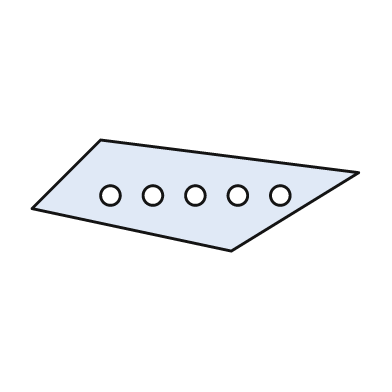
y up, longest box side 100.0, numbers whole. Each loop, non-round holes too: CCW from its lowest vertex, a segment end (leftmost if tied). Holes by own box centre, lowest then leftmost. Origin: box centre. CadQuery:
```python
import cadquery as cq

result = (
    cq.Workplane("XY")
    .moveTo(11.0, -17.0)
    .lineTo(50.0, 7.0)
    .lineTo(-29.0, 17.0)
    .lineTo(-50.0, -4.0)
    .close()
    .moveTo(-26.0, 0.0)
    .circle(3.0)
    .moveTo(-13.0, 0.0)
    .circle(3.0)
    .moveTo(0.0, 0.0)
    .circle(3.0)
    .moveTo(13.0, 0.0)
    .circle(3.0)
    .moveTo(26.0, 0.0)
    .circle(3.0)
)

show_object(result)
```